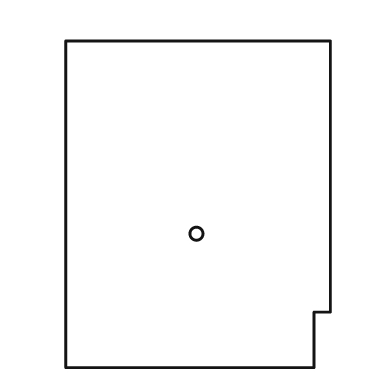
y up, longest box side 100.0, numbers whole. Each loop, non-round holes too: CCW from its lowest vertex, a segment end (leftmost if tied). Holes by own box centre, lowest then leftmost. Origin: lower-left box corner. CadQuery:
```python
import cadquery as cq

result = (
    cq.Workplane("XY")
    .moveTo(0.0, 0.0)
    .lineTo(76.0, 0.0)
    .lineTo(76.0, 17.0)
    .lineTo(81.0, 17.0)
    .lineTo(81.0, 100.0)
    .lineTo(0.0, 100.0)
    .close()
    .moveTo(40.0, 41.0)
    .circle(2.0)
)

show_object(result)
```